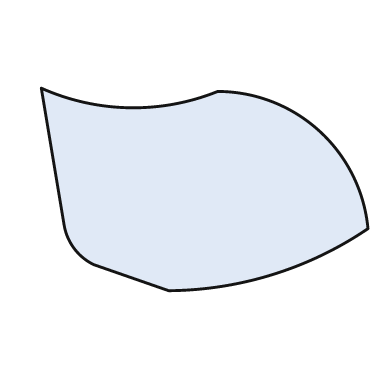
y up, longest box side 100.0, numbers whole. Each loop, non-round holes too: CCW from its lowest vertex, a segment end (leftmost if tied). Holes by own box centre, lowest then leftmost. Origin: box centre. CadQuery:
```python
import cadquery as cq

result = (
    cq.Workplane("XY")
    .moveTo(-11.0, -31.0)
    .threePointArc((21.0, -26.0), (50.0, -12.0))
    .threePointArc((35.0, 18.0), (4.0, 30.0))
    .threePointArc((-23.0, 25.0), (-50.0, 31.0))
    .lineTo(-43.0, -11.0)
    .threePointArc((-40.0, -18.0), (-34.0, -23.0))
    .close()
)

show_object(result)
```